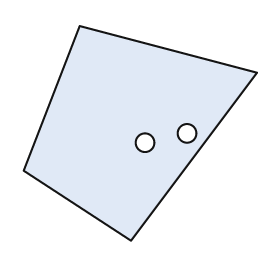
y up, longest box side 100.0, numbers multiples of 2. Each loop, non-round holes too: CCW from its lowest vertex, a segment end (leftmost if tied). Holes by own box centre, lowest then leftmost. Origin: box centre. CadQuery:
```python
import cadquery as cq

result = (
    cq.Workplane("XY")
    .moveTo(-4.0, -46.0)
    .lineTo(50.0, 26.0)
    .lineTo(-26.0, 46.0)
    .lineTo(-50.0, -16.0)
    .close()
    .moveTo(2.0, -4.0)
    .circle(4.0)
    .moveTo(20.0, 0.0)
    .circle(4.0)
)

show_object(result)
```